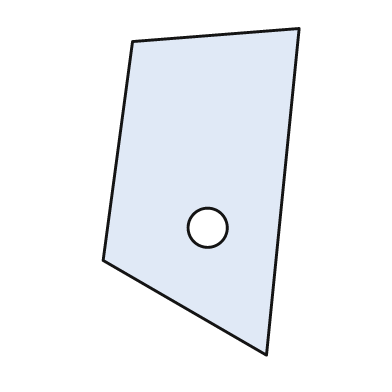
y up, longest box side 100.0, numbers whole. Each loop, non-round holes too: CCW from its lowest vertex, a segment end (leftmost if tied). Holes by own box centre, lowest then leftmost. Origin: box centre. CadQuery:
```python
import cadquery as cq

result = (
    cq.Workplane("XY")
    .moveTo(20.0, -50.0)
    .lineTo(30.0, 50.0)
    .lineTo(-21.0, 46.0)
    .lineTo(-30.0, -21.0)
    .close()
    .moveTo(2.0, -11.0)
    .circle(6.0)
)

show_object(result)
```